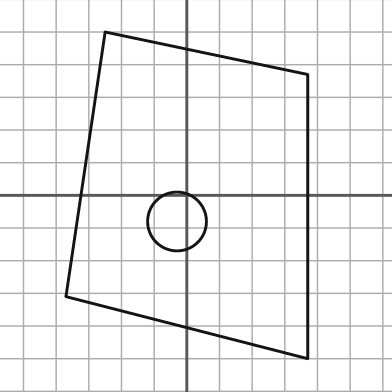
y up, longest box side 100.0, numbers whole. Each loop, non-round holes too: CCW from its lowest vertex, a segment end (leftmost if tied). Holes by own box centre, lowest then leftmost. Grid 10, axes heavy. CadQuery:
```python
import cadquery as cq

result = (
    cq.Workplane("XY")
    .moveTo(37.0, -50.0)
    .lineTo(37.0, 37.0)
    .lineTo(-25.0, 50.0)
    .lineTo(-37.0, -31.0)
    .close()
    .moveTo(-3.0, -8.0)
    .circle(9.0)
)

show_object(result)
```